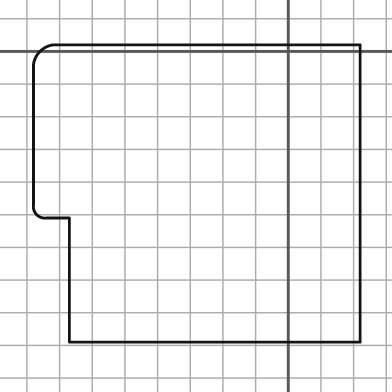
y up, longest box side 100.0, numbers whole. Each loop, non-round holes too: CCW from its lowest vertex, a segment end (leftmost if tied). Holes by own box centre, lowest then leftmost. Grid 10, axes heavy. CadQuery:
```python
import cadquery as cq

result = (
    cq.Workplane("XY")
    .moveTo(-67.0, -89.0)
    .lineTo(22.0, -89.0)
    .lineTo(22.0, 2.0)
    .lineTo(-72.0, 2.0)
    .threePointArc((-76.0, 0.0), (-78.0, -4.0))
    .lineTo(-78.0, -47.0)
    .threePointArc((-77.0, -50.0), (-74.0, -51.0))
    .lineTo(-67.0, -51.0)
    .close()
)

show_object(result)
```